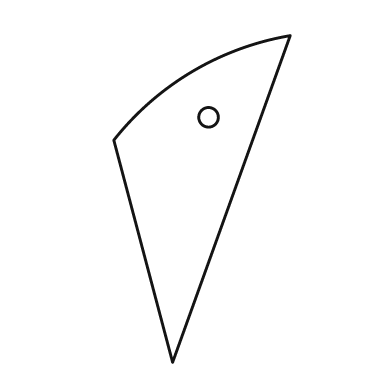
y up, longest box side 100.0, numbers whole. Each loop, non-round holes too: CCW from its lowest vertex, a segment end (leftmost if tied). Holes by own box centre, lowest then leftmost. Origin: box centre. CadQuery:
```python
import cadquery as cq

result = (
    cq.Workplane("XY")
    .moveTo(-9.0, -50.0)
    .lineTo(27.0, 50.0)
    .threePointArc((-3.0, 39.0), (-27.0, 18.0))
    .close()
    .moveTo(2.0, 25.0)
    .circle(3.0)
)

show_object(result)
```